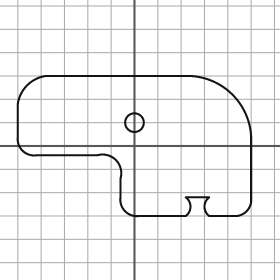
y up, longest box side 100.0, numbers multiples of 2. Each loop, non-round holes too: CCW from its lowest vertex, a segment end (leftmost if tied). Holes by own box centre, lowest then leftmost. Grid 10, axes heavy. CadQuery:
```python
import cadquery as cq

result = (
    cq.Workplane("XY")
    .moveTo(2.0, -30.0)
    .lineTo(22.0, -30.0)
    .threePointArc((24.0, -26.0), (22.0, -22.0))
    .lineTo(32.0, -22.0)
    .threePointArc((30.0, -26.0), (32.0, -30.0))
    .lineTo(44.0, -30.0)
    .threePointArc((48.0, -28.0), (50.0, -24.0))
    .lineTo(50.0, 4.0)
    .threePointArc((42.0, 22.0), (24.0, 30.0))
    .lineTo(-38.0, 30.0)
    .threePointArc((-46.0, 26.0), (-50.0, 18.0))
    .lineTo(-50.0, 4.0)
    .threePointArc((-48.0, -2.0), (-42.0, -4.0))
    .lineTo(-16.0, -4.0)
    .threePointArc((-8.0, -6.0), (-6.0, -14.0))
    .lineTo(-6.0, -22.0)
    .threePointArc((-4.0, -28.0), (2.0, -30.0))
    .close()
    .moveTo(0.0, 10.0)
    .circle(4.0)
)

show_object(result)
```